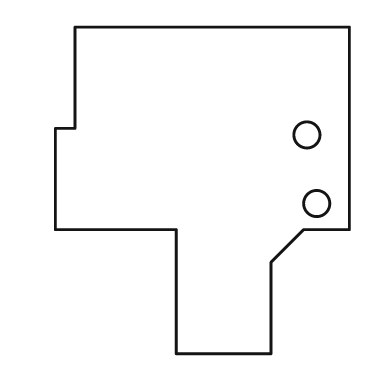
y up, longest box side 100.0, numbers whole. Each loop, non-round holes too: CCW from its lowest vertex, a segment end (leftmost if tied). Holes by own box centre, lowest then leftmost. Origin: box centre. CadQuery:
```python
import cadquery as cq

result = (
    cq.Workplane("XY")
    .moveTo(-8.0, -50.0)
    .lineTo(21.0, -50.0)
    .lineTo(21.0, -22.0)
    .lineTo(31.0, -12.0)
    .lineTo(45.0, -12.0)
    .lineTo(45.0, 50.0)
    .lineTo(-39.0, 50.0)
    .lineTo(-39.0, 19.0)
    .lineTo(-45.0, 19.0)
    .lineTo(-45.0, -12.0)
    .lineTo(-8.0, -12.0)
    .close()
    .moveTo(35.0, -4.0)
    .circle(4.0)
    .moveTo(32.0, 17.0)
    .circle(4.0)
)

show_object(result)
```